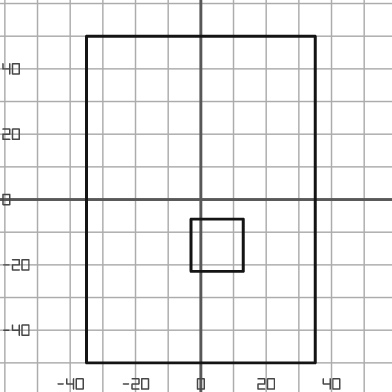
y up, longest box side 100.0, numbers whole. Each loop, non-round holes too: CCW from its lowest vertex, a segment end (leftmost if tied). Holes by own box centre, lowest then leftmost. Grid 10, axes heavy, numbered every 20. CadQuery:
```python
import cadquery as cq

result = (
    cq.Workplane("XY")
    .moveTo(-35.0, -50.0)
    .lineTo(35.0, -50.0)
    .lineTo(35.0, 50.0)
    .lineTo(-35.0, 50.0)
    .close()
    .moveTo(-3.0, -22.0)
    .lineTo(13.0, -22.0)
    .lineTo(13.0, -6.0)
    .lineTo(-3.0, -6.0)
    .close()
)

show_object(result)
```